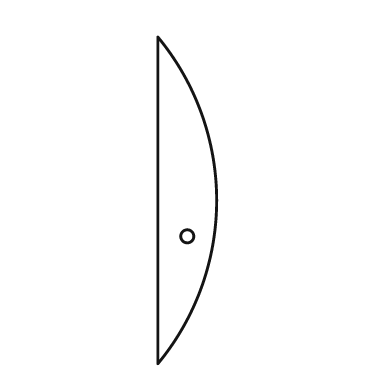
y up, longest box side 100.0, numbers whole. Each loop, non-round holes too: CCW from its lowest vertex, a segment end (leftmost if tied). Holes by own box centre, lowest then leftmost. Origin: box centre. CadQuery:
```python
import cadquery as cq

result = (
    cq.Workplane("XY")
    .moveTo(-9.0, -50.0)
    .threePointArc((9.0, 0.0), (-9.0, 50.0))
    .close()
    .moveTo(0.0, -11.0)
    .circle(2.0)
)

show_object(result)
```